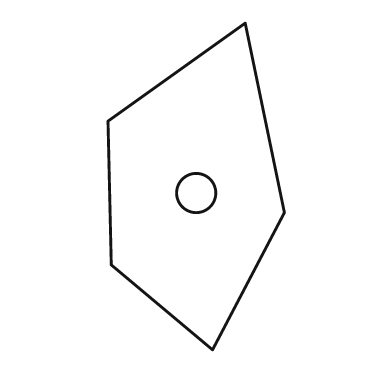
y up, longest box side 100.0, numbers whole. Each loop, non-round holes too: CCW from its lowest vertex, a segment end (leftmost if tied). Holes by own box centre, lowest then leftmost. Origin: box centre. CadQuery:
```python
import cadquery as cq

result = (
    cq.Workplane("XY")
    .moveTo(5.0, -50.0)
    .lineTo(27.0, -8.0)
    .lineTo(15.0, 50.0)
    .lineTo(-27.0, 20.0)
    .lineTo(-26.0, -24.0)
    .close()
    .moveTo(0.0, -2.0)
    .circle(6.0)
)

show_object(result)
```